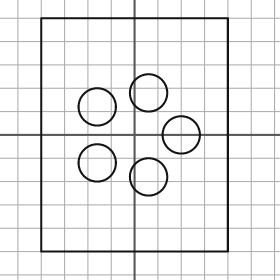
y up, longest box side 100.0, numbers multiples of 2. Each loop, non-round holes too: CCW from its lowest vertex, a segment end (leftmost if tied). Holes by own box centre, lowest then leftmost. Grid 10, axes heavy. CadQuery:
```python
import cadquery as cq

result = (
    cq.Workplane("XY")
    .moveTo(-40.0, -50.0)
    .lineTo(40.0, -50.0)
    .lineTo(40.0, 50.0)
    .lineTo(-40.0, 50.0)
    .close()
    .moveTo(6.0, -18.0)
    .circle(8.0)
    .moveTo(-16.0, -12.0)
    .circle(8.0)
    .moveTo(20.0, 0.0)
    .circle(8.0)
    .moveTo(-16.0, 12.0)
    .circle(8.0)
    .moveTo(6.0, 18.0)
    .circle(8.0)
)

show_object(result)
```